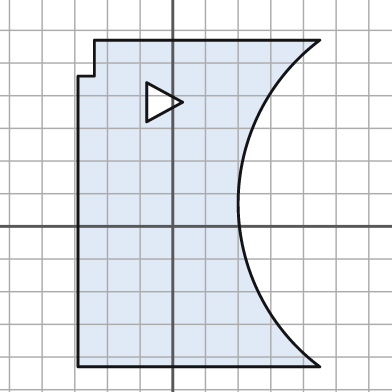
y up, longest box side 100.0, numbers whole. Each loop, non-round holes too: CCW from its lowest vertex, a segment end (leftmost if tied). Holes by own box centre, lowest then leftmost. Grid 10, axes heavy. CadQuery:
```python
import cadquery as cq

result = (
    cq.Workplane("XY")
    .moveTo(-29.0, -43.0)
    .lineTo(45.0, -43.0)
    .threePointArc((20.0, 7.0), (45.0, 57.0))
    .lineTo(-24.0, 57.0)
    .lineTo(-24.0, 46.0)
    .lineTo(-29.0, 46.0)
    .close()
    .moveTo(-8.0, 32.0)
    .lineTo(3.0, 38.0)
    .lineTo(-8.0, 44.0)
    .close()
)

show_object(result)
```